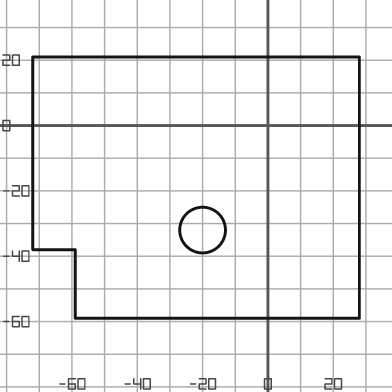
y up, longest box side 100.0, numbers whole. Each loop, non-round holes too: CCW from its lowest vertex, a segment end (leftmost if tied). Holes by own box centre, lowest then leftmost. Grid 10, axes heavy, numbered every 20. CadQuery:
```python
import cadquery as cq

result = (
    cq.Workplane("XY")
    .moveTo(-59.0, -59.0)
    .lineTo(28.0, -59.0)
    .lineTo(28.0, 21.0)
    .lineTo(-72.0, 21.0)
    .lineTo(-72.0, -38.0)
    .lineTo(-59.0, -38.0)
    .close()
    .moveTo(-20.0, -32.0)
    .circle(7.0)
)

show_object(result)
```